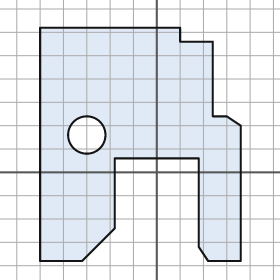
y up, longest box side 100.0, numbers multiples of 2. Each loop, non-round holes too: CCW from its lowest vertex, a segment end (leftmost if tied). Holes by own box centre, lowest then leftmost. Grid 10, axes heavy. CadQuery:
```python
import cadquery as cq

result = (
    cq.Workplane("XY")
    .moveTo(-50.0, -38.0)
    .lineTo(-32.0, -38.0)
    .lineTo(-18.0, -24.0)
    .lineTo(-18.0, 6.0)
    .lineTo(18.0, 6.0)
    .lineTo(18.0, -32.0)
    .lineTo(22.0, -38.0)
    .lineTo(36.0, -38.0)
    .lineTo(36.0, 20.0)
    .lineTo(30.0, 24.0)
    .lineTo(24.0, 24.0)
    .lineTo(24.0, 56.0)
    .lineTo(10.0, 56.0)
    .lineTo(10.0, 62.0)
    .lineTo(-50.0, 62.0)
    .close()
    .moveTo(-30.0, 16.0)
    .circle(8.0)
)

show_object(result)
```